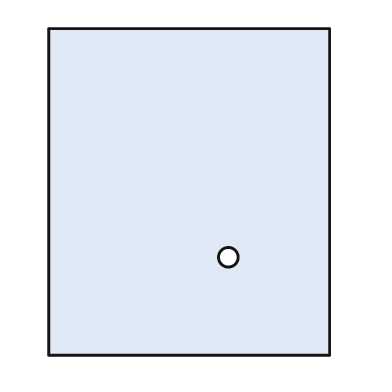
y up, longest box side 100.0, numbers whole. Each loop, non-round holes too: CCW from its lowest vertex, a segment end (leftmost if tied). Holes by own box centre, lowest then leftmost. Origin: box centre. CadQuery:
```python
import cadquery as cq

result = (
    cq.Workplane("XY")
    .moveTo(-43.0, -50.0)
    .lineTo(43.0, -50.0)
    .lineTo(43.0, 50.0)
    .lineTo(-43.0, 50.0)
    .close()
    .moveTo(12.0, -20.0)
    .circle(3.0)
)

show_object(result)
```